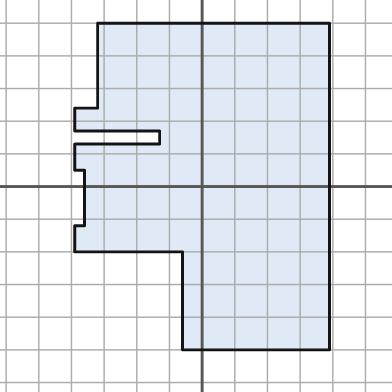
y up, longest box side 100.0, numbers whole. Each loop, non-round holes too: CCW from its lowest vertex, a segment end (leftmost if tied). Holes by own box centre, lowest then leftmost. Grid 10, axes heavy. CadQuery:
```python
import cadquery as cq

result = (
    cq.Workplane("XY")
    .moveTo(-6.0, -50.0)
    .lineTo(39.0, -50.0)
    .lineTo(39.0, 50.0)
    .lineTo(-32.0, 50.0)
    .lineTo(-32.0, 24.0)
    .lineTo(-39.0, 24.0)
    .lineTo(-39.0, 17.0)
    .lineTo(-13.0, 17.0)
    .lineTo(-13.0, 13.0)
    .lineTo(-39.0, 13.0)
    .lineTo(-39.0, 5.0)
    .lineTo(-36.0, 5.0)
    .lineTo(-36.0, -12.0)
    .lineTo(-39.0, -12.0)
    .lineTo(-39.0, -20.0)
    .lineTo(-6.0, -20.0)
    .close()
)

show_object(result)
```